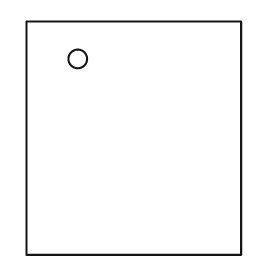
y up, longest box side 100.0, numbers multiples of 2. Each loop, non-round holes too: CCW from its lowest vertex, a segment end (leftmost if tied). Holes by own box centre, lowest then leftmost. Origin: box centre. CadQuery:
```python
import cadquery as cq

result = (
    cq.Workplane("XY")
    .moveTo(-46.0, -50.0)
    .lineTo(46.0, -50.0)
    .lineTo(46.0, 50.0)
    .lineTo(-46.0, 50.0)
    .close()
    .moveTo(-24.0, 34.0)
    .circle(4.0)
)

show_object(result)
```